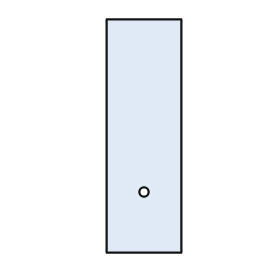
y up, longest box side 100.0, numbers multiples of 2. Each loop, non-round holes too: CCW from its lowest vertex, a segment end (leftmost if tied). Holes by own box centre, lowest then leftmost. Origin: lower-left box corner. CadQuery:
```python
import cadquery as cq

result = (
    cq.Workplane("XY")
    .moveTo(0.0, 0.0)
    .lineTo(32.0, 0.0)
    .lineTo(32.0, 100.0)
    .lineTo(0.0, 100.0)
    .close()
    .moveTo(16.0, 26.0)
    .circle(2.0)
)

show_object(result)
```